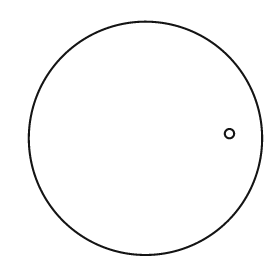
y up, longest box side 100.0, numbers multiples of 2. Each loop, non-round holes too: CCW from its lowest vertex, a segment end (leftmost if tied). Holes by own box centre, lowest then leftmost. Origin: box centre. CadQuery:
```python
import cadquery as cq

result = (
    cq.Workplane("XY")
    .moveTo(0.0, 0.0)
    .circle(50.0)
    .moveTo(36.0, 2.0)
    .circle(2.0)
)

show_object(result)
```